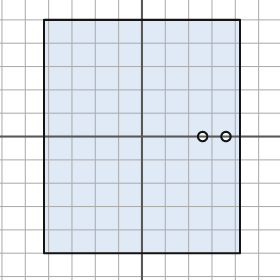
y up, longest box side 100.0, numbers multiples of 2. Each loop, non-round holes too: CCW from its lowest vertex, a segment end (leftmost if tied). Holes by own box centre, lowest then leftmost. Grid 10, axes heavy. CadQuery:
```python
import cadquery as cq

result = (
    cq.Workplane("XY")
    .moveTo(-42.0, -50.0)
    .lineTo(42.0, -50.0)
    .lineTo(42.0, 50.0)
    .lineTo(-42.0, 50.0)
    .close()
    .moveTo(26.0, 0.0)
    .circle(2.0)
    .moveTo(36.0, 0.0)
    .circle(2.0)
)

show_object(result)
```